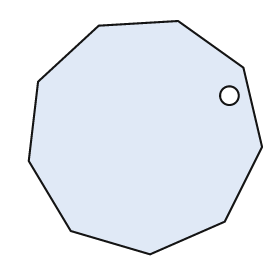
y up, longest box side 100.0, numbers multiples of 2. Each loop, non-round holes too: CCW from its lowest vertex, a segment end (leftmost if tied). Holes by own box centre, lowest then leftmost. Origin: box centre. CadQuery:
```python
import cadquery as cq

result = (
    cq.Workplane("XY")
    .moveTo(2.0, -50.0)
    .lineTo(34.0, -36.0)
    .lineTo(50.0, -4.0)
    .lineTo(42.0, 30.0)
    .lineTo(14.0, 50.0)
    .lineTo(-20.0, 48.0)
    .lineTo(-46.0, 24.0)
    .lineTo(-50.0, -10.0)
    .lineTo(-32.0, -40.0)
    .close()
    .moveTo(36.0, 18.0)
    .circle(4.0)
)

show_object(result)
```